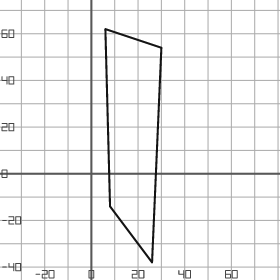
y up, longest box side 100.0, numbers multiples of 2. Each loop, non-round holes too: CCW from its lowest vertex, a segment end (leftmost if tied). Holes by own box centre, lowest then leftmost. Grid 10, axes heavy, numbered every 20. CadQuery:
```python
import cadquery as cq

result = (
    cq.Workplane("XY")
    .moveTo(26.0, -38.0)
    .lineTo(30.0, 54.0)
    .lineTo(6.0, 62.0)
    .lineTo(8.0, -14.0)
    .close()
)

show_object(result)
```